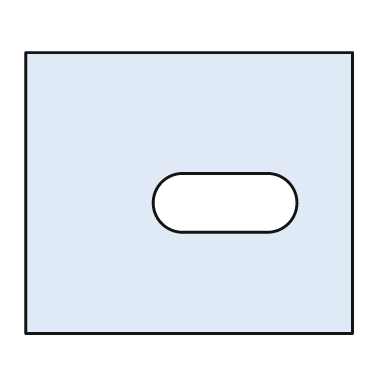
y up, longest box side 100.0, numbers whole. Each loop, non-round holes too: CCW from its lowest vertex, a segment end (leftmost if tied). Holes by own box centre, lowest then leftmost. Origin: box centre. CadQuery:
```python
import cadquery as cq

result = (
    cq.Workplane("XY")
    .moveTo(-50.0, -43.0)
    .lineTo(50.0, -43.0)
    .lineTo(50.0, 43.0)
    .lineTo(-50.0, 43.0)
    .close()
    .moveTo(-2.0, -12.0)
    .lineTo(24.0, -12.0)
    .threePointArc((33.0, -3.0), (24.0, 6.0))
    .lineTo(-2.0, 6.0)
    .threePointArc((-11.0, -3.0), (-2.0, -12.0))
    .close()
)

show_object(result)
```